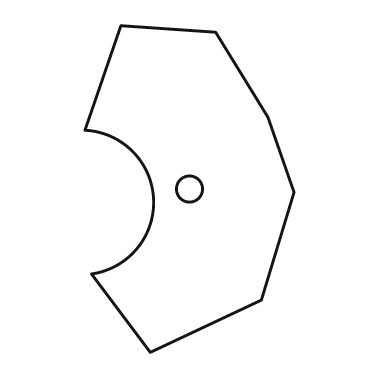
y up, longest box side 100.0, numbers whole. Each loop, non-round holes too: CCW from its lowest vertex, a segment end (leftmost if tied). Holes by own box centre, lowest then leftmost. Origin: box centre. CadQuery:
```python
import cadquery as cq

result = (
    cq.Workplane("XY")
    .moveTo(-12.0, -50.0)
    .lineTo(22.0, -34.0)
    .lineTo(32.0, -1.0)
    .lineTo(24.0, 22.0)
    .lineTo(8.0, 48.0)
    .lineTo(-21.0, 50.0)
    .lineTo(-32.0, 18.0)
    .threePointArc((-11.0, -3.0), (-30.0, -26.0))
    .close()
    .moveTo(0.0, 0.0)
    .circle(4.0)
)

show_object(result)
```